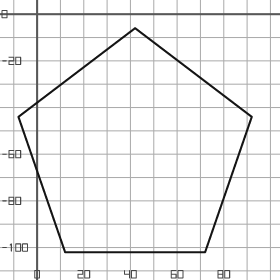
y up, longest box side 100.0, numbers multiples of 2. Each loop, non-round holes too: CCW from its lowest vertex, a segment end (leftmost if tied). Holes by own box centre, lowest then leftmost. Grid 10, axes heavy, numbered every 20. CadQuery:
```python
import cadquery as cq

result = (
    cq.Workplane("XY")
    .moveTo(12.0, -102.0)
    .lineTo(72.0, -102.0)
    .lineTo(92.0, -44.0)
    .lineTo(42.0, -6.0)
    .lineTo(-8.0, -44.0)
    .close()
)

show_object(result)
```